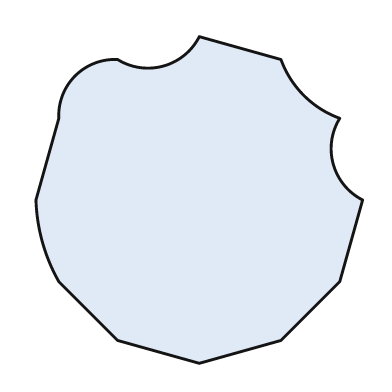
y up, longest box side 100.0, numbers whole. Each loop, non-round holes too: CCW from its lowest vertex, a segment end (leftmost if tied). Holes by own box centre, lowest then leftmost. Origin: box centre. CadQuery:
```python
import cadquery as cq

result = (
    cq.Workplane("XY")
    .moveTo(0.0, -50.0)
    .lineTo(25.0, -43.0)
    .lineTo(43.0, -25.0)
    .lineTo(50.0, 0.0)
    .threePointArc((41.0, 11.0), (43.0, 25.0))
    .threePointArc((32.0, 32.0), (25.0, 43.0))
    .lineTo(0.0, 50.0)
    .threePointArc((-11.0, 41.0), (-25.0, 43.0))
    .threePointArc((-38.0, 38.0), (-43.0, 25.0))
    .lineTo(-50.0, 0.0)
    .threePointArc((-48.0, -13.0), (-43.0, -25.0))
    .lineTo(-25.0, -43.0)
    .close()
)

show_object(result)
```